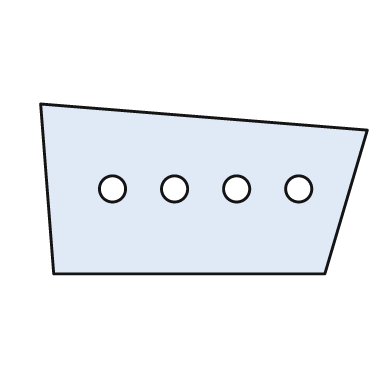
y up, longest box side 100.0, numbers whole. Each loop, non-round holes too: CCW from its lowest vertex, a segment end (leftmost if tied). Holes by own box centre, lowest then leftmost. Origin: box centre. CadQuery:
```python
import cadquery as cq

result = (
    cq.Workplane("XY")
    .moveTo(-46.0, -26.0)
    .lineTo(37.0, -26.0)
    .lineTo(50.0, 18.0)
    .lineTo(-50.0, 26.0)
    .close()
    .moveTo(-28.0, 0.0)
    .circle(4.0)
    .moveTo(-9.0, 0.0)
    .circle(4.0)
    .moveTo(10.0, 0.0)
    .circle(4.0)
    .moveTo(29.0, 0.0)
    .circle(4.0)
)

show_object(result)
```